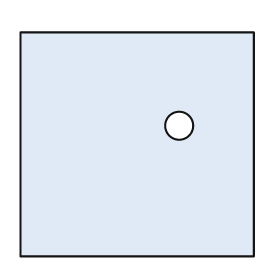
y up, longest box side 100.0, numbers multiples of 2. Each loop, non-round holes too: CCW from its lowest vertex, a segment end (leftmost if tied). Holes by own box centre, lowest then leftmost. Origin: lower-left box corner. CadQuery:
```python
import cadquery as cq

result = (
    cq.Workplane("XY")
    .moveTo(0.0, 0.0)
    .lineTo(100.0, 0.0)
    .lineTo(100.0, 96.0)
    .lineTo(0.0, 96.0)
    .close()
    .moveTo(68.0, 56.0)
    .circle(6.0)
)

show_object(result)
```